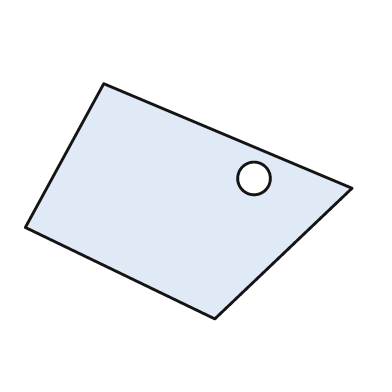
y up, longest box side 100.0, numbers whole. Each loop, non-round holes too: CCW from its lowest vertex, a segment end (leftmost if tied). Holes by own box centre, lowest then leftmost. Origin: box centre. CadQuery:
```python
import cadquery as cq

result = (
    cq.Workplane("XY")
    .moveTo(8.0, -36.0)
    .lineTo(50.0, 4.0)
    .lineTo(-26.0, 36.0)
    .lineTo(-50.0, -8.0)
    .close()
    .moveTo(20.0, 7.0)
    .circle(5.0)
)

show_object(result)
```